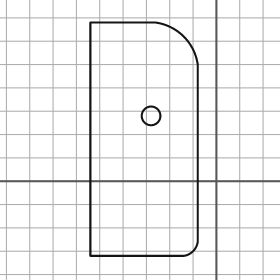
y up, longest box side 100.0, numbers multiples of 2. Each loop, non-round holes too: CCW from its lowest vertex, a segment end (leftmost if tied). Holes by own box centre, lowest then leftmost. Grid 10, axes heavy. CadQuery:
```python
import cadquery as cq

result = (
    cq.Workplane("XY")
    .moveTo(-54.0, -32.0)
    .lineTo(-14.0, -32.0)
    .threePointArc((-10.0, -30.0), (-8.0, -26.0))
    .lineTo(-8.0, 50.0)
    .threePointArc((-14.0, 62.0), (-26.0, 68.0))
    .lineTo(-54.0, 68.0)
    .close()
    .moveTo(-28.0, 28.0)
    .circle(4.0)
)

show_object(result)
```